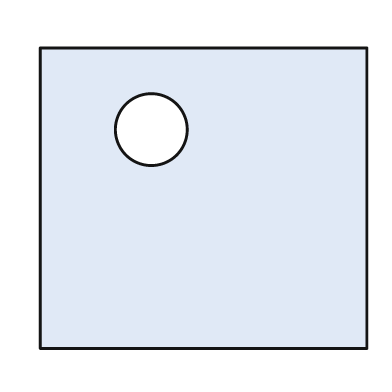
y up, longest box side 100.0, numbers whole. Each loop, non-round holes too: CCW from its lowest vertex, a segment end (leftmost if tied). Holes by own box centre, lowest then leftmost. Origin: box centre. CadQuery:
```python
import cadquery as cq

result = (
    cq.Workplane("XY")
    .moveTo(-50.0, -46.0)
    .lineTo(50.0, -46.0)
    .lineTo(50.0, 46.0)
    .lineTo(-50.0, 46.0)
    .close()
    .moveTo(-16.0, 21.0)
    .circle(11.0)
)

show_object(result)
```